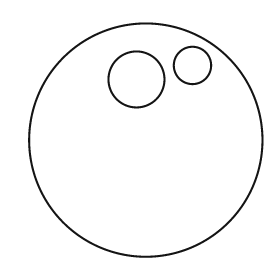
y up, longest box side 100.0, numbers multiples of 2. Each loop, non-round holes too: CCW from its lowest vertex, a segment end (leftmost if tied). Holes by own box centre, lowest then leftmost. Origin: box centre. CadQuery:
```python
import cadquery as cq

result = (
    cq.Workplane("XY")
    .moveTo(0.0, 0.0)
    .circle(50.0)
    .moveTo(-4.0, 26.0)
    .circle(12.0)
    .moveTo(20.0, 32.0)
    .circle(8.0)
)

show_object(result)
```